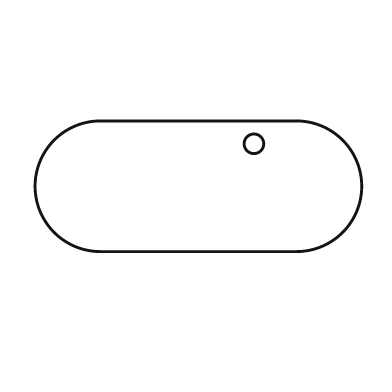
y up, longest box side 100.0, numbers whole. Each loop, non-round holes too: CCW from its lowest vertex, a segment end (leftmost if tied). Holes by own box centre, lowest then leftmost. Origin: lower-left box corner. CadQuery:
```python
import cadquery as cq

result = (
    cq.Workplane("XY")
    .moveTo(20.0, 0.0)
    .lineTo(80.0, 0.0)
    .threePointArc((100.0, 20.0), (80.0, 40.0))
    .lineTo(20.0, 40.0)
    .threePointArc((0.0, 20.0), (20.0, 0.0))
    .close()
    .moveTo(67.0, 33.0)
    .circle(3.0)
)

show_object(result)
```